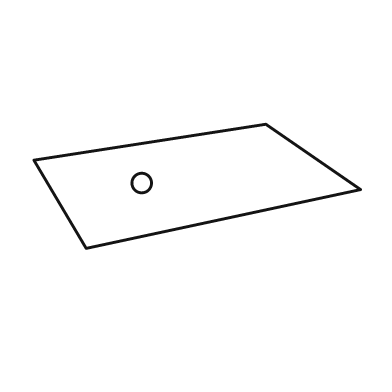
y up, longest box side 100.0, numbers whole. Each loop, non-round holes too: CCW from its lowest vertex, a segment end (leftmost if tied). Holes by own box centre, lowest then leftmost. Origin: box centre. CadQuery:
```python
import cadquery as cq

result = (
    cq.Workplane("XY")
    .moveTo(-34.0, -19.0)
    .lineTo(50.0, -1.0)
    .lineTo(21.0, 19.0)
    .lineTo(-50.0, 8.0)
    .close()
    .moveTo(-17.0, 1.0)
    .circle(3.0)
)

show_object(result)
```